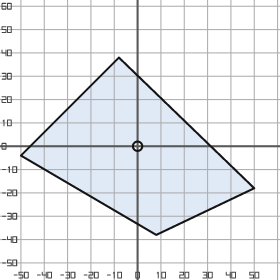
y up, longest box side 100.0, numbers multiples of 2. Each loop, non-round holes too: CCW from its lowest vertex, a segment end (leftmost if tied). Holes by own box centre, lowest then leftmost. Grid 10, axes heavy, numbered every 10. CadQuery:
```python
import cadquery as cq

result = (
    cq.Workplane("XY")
    .moveTo(8.0, -38.0)
    .lineTo(50.0, -18.0)
    .lineTo(-8.0, 38.0)
    .lineTo(-50.0, -4.0)
    .close()
    .moveTo(0.0, 0.0)
    .circle(2.0)
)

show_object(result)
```